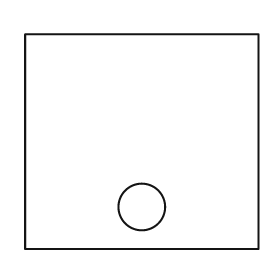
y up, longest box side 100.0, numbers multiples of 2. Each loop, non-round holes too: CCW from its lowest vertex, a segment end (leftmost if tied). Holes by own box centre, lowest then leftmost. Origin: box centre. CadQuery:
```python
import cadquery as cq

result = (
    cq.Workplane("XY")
    .moveTo(-50.0, -46.0)
    .lineTo(50.0, -46.0)
    .lineTo(50.0, 46.0)
    .lineTo(-50.0, 46.0)
    .close()
    .moveTo(0.0, -28.0)
    .circle(10.0)
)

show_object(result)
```